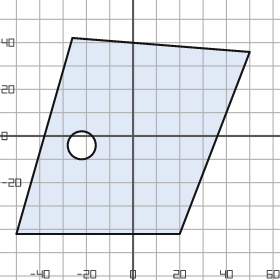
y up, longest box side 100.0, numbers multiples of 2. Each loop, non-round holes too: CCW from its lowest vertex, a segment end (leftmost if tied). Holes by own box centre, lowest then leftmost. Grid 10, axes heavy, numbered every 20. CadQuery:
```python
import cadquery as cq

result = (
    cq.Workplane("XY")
    .moveTo(-50.0, -42.0)
    .lineTo(20.0, -42.0)
    .lineTo(50.0, 36.0)
    .lineTo(-26.0, 42.0)
    .close()
    .moveTo(-22.0, -4.0)
    .circle(6.0)
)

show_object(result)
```